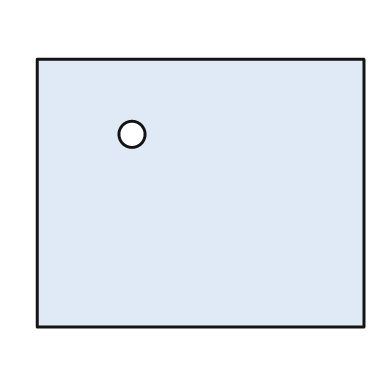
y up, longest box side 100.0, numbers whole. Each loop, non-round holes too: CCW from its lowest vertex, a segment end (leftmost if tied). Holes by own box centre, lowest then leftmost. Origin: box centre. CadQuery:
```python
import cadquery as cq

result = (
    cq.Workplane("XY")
    .moveTo(-50.0, -41.0)
    .lineTo(50.0, -41.0)
    .lineTo(50.0, 41.0)
    .lineTo(-50.0, 41.0)
    .close()
    .moveTo(-21.0, 18.0)
    .circle(4.0)
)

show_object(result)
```